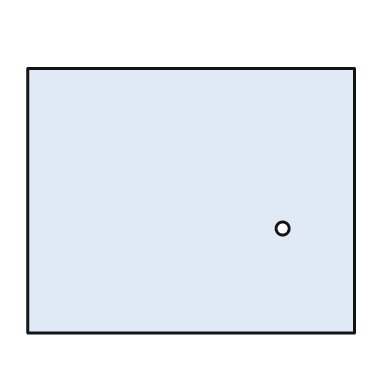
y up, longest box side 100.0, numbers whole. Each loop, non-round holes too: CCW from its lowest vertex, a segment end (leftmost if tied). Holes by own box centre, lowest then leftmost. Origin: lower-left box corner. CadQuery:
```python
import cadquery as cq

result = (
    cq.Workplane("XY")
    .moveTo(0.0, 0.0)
    .lineTo(100.0, 0.0)
    .lineTo(100.0, 81.0)
    .lineTo(0.0, 81.0)
    .close()
    .moveTo(78.0, 32.0)
    .circle(2.0)
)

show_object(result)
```